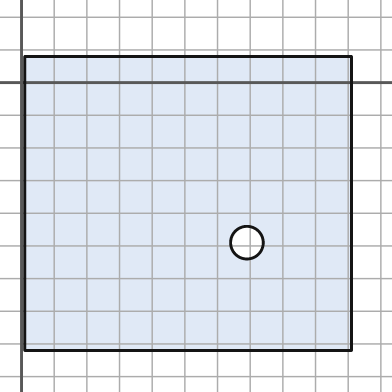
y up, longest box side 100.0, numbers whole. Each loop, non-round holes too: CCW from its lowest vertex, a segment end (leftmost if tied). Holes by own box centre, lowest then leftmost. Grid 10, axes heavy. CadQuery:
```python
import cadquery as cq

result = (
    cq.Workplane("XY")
    .moveTo(1.0, -82.0)
    .lineTo(101.0, -82.0)
    .lineTo(101.0, 8.0)
    .lineTo(1.0, 8.0)
    .close()
    .moveTo(69.0, -49.0)
    .circle(5.0)
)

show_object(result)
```